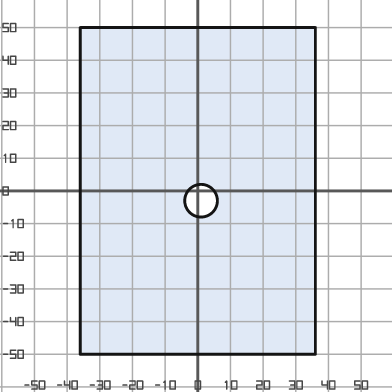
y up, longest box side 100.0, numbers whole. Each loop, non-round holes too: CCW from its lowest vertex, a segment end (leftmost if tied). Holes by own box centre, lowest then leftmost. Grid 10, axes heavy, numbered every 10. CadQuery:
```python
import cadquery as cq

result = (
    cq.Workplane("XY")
    .moveTo(-36.0, -50.0)
    .lineTo(36.0, -50.0)
    .lineTo(36.0, 50.0)
    .lineTo(-36.0, 50.0)
    .close()
    .moveTo(1.0, -3.0)
    .circle(5.0)
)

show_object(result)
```